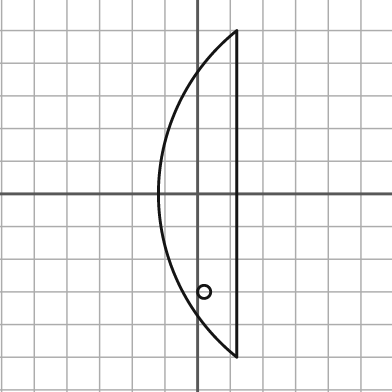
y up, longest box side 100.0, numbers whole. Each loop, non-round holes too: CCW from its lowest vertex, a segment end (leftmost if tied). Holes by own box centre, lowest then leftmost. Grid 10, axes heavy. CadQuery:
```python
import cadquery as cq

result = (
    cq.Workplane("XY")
    .moveTo(12.0, -50.0)
    .lineTo(12.0, 50.0)
    .threePointArc((-12.0, 0.0), (12.0, -50.0))
    .close()
    .moveTo(2.0, -30.0)
    .circle(2.0)
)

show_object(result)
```